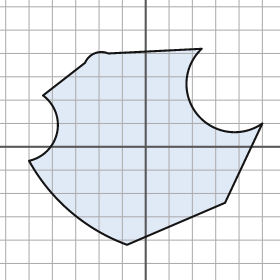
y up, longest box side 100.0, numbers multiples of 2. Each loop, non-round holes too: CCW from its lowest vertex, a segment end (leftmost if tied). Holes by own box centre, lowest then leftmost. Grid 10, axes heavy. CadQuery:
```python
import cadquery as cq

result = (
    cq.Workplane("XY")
    .moveTo(-8.0, -42.0)
    .lineTo(34.0, -24.0)
    .lineTo(50.0, 10.0)
    .threePointArc((22.0, 14.0), (24.0, 42.0))
    .lineTo(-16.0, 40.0)
    .threePointArc((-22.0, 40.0), (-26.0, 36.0))
    .lineTo(-44.0, 22.0)
    .threePointArc((-38.0, 6.0), (-50.0, -6.0))
    .threePointArc((-32.0, -28.0), (-8.0, -42.0))
    .close()
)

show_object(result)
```